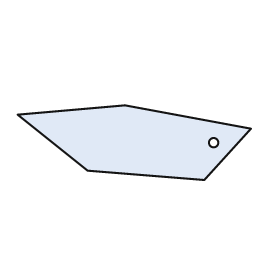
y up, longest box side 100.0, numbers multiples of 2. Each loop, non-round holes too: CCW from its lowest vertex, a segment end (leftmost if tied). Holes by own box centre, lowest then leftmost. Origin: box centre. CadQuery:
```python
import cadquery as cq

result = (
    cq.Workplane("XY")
    .moveTo(30.0, -16.0)
    .lineTo(50.0, 6.0)
    .lineTo(-4.0, 16.0)
    .lineTo(-50.0, 12.0)
    .lineTo(-20.0, -12.0)
    .close()
    .moveTo(34.0, 0.0)
    .circle(2.0)
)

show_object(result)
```